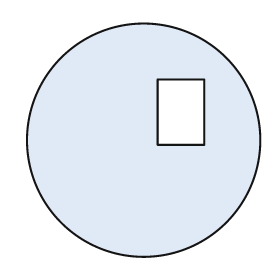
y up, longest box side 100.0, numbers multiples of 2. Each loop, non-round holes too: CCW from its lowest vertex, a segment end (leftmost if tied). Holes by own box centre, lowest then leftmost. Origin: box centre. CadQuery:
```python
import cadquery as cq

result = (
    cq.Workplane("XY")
    .moveTo(0.0, 0.0)
    .circle(50.0)
    .moveTo(6.0, -2.0)
    .lineTo(26.0, -2.0)
    .lineTo(26.0, 26.0)
    .lineTo(6.0, 26.0)
    .close()
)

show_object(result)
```